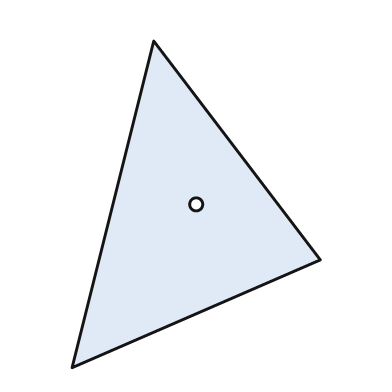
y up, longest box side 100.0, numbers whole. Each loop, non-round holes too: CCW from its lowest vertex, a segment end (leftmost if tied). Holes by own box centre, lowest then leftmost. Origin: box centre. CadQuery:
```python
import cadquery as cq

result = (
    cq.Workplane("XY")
    .moveTo(-38.0, -50.0)
    .lineTo(38.0, -17.0)
    .lineTo(-13.0, 50.0)
    .close()
    .moveTo(0.0, 0.0)
    .circle(2.0)
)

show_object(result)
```